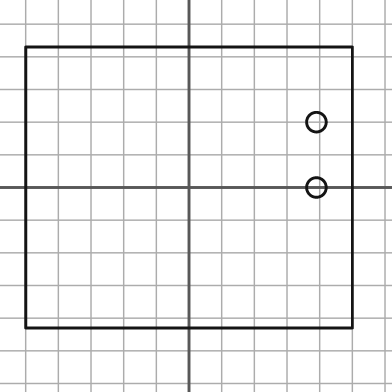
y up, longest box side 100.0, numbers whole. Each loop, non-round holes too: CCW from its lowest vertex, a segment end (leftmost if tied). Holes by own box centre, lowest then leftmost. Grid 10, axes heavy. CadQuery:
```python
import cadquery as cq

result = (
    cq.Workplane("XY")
    .moveTo(-50.0, -43.0)
    .lineTo(50.0, -43.0)
    .lineTo(50.0, 43.0)
    .lineTo(-50.0, 43.0)
    .close()
    .moveTo(39.0, 0.0)
    .circle(3.0)
    .moveTo(39.0, 20.0)
    .circle(3.0)
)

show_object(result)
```